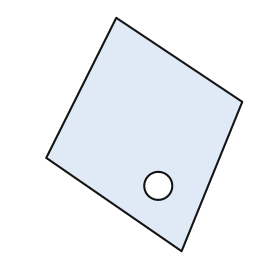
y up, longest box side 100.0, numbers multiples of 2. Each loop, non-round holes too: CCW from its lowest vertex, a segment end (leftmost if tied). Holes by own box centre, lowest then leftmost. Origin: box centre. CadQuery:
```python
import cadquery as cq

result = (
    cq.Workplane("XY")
    .moveTo(16.0, -50.0)
    .lineTo(42.0, 14.0)
    .lineTo(-12.0, 50.0)
    .lineTo(-42.0, -10.0)
    .close()
    .moveTo(6.0, -22.0)
    .circle(6.0)
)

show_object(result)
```